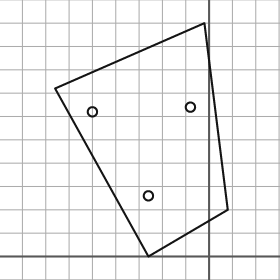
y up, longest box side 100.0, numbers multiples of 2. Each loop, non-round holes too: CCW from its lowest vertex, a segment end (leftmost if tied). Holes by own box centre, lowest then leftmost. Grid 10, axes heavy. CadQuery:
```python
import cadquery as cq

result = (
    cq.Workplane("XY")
    .moveTo(-26.0, 0.0)
    .lineTo(8.0, 20.0)
    .lineTo(-2.0, 100.0)
    .lineTo(-66.0, 72.0)
    .close()
    .moveTo(-26.0, 26.0)
    .circle(2.0)
    .moveTo(-50.0, 62.0)
    .circle(2.0)
    .moveTo(-8.0, 64.0)
    .circle(2.0)
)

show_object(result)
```